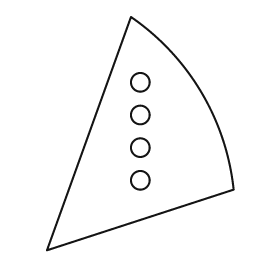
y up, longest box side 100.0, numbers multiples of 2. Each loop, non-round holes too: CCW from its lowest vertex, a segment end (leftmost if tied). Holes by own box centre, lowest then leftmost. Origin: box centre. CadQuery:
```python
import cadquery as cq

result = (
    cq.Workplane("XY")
    .moveTo(-40.0, -50.0)
    .lineTo(40.0, -24.0)
    .threePointArc((26.0, 18.0), (-4.0, 50.0))
    .close()
    .moveTo(0.0, -20.0)
    .circle(4.0)
    .moveTo(0.0, -6.0)
    .circle(4.0)
    .moveTo(0.0, 8.0)
    .circle(4.0)
    .moveTo(0.0, 22.0)
    .circle(4.0)
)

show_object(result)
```